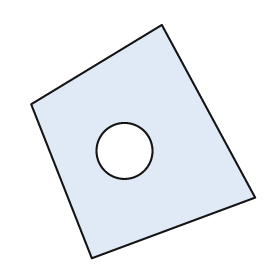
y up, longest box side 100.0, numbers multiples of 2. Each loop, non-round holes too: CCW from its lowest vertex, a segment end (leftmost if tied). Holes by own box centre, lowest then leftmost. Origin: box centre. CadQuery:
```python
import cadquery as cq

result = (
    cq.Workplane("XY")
    .moveTo(-22.0, -50.0)
    .lineTo(48.0, -24.0)
    .lineTo(8.0, 50.0)
    .lineTo(-48.0, 16.0)
    .close()
    .moveTo(-8.0, -4.0)
    .circle(12.0)
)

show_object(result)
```